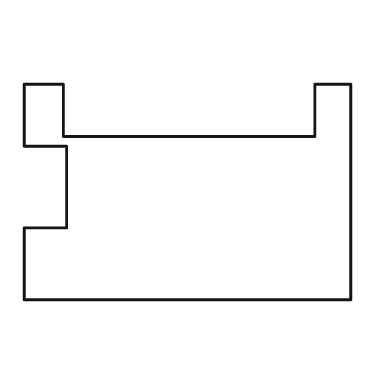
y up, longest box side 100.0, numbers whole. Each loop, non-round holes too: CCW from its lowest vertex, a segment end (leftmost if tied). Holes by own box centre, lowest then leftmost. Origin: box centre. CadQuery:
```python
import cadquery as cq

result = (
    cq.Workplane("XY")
    .moveTo(-50.0, -33.0)
    .lineTo(50.0, -33.0)
    .lineTo(50.0, 33.0)
    .lineTo(39.0, 33.0)
    .lineTo(39.0, 17.0)
    .lineTo(-38.0, 17.0)
    .lineTo(-38.0, 33.0)
    .lineTo(-50.0, 33.0)
    .lineTo(-50.0, 14.0)
    .lineTo(-37.0, 14.0)
    .lineTo(-37.0, -11.0)
    .lineTo(-50.0, -11.0)
    .close()
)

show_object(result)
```